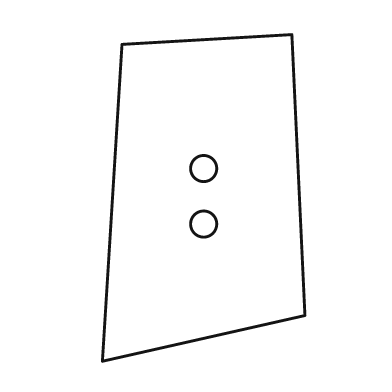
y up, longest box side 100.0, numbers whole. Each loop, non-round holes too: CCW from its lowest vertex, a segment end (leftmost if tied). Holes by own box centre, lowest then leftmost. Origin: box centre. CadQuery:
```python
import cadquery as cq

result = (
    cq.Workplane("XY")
    .moveTo(-31.0, -50.0)
    .lineTo(31.0, -36.0)
    .lineTo(27.0, 50.0)
    .lineTo(-25.0, 47.0)
    .close()
    .moveTo(0.0, -8.0)
    .circle(4.0)
    .moveTo(0.0, 9.0)
    .circle(4.0)
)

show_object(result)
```